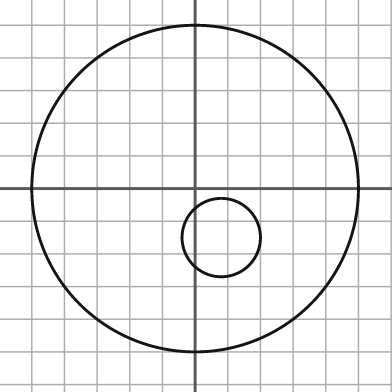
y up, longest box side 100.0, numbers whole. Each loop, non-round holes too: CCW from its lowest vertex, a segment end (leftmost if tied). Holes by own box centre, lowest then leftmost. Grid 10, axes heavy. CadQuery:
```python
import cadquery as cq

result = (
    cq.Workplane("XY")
    .moveTo(0.0, 0.0)
    .circle(50.0)
    .moveTo(8.0, -15.0)
    .circle(12.0)
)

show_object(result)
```